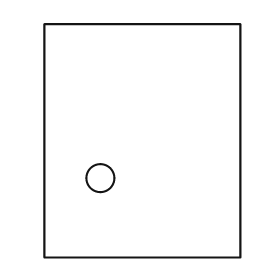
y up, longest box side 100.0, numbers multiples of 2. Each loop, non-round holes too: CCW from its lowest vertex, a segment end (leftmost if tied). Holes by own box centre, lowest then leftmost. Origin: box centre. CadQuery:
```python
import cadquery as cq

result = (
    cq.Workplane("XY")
    .moveTo(-42.0, -50.0)
    .lineTo(42.0, -50.0)
    .lineTo(42.0, 50.0)
    .lineTo(-42.0, 50.0)
    .close()
    .moveTo(-18.0, -16.0)
    .circle(6.0)
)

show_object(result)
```